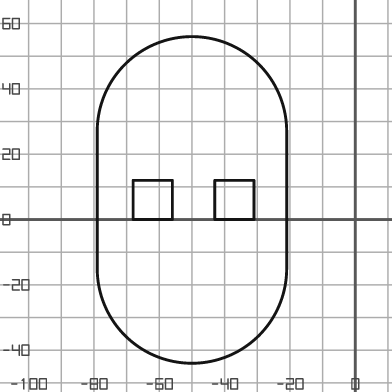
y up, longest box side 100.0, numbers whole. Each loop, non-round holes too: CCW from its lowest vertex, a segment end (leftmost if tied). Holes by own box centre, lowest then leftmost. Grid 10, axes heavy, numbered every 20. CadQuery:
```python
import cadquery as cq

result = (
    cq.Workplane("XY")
    .moveTo(-79.0, -15.0)
    .threePointArc((-50.0, -44.0), (-21.0, -15.0))
    .lineTo(-21.0, 27.0)
    .threePointArc((-50.0, 56.0), (-79.0, 27.0))
    .close()
    .moveTo(-68.0, 0.0)
    .lineTo(-56.0, 0.0)
    .lineTo(-56.0, 12.0)
    .lineTo(-68.0, 12.0)
    .close()
    .moveTo(-43.0, 0.0)
    .lineTo(-31.0, 0.0)
    .lineTo(-31.0, 12.0)
    .lineTo(-43.0, 12.0)
    .close()
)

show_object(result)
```